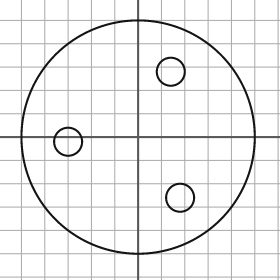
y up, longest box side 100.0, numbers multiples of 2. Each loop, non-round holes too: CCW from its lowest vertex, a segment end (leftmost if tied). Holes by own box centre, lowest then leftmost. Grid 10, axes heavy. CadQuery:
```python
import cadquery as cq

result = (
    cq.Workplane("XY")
    .moveTo(0.0, 0.0)
    .circle(50.0)
    .moveTo(18.0, -26.0)
    .circle(6.0)
    .moveTo(-30.0, -2.0)
    .circle(6.0)
    .moveTo(14.0, 28.0)
    .circle(6.0)
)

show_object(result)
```